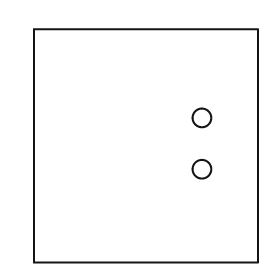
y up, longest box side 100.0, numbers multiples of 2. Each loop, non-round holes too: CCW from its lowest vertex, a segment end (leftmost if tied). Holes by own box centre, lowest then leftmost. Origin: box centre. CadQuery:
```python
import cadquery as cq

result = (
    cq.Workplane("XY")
    .moveTo(-48.0, -50.0)
    .lineTo(48.0, -50.0)
    .lineTo(48.0, 50.0)
    .lineTo(-48.0, 50.0)
    .close()
    .moveTo(24.0, -10.0)
    .circle(4.0)
    .moveTo(24.0, 12.0)
    .circle(4.0)
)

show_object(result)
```